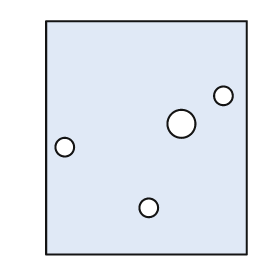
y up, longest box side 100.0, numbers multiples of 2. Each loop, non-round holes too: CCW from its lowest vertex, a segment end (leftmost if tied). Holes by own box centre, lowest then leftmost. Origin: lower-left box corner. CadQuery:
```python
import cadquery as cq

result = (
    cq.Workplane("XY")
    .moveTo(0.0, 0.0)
    .lineTo(86.0, 0.0)
    .lineTo(86.0, 100.0)
    .lineTo(0.0, 100.0)
    .close()
    .moveTo(44.0, 20.0)
    .circle(4.0)
    .moveTo(8.0, 46.0)
    .circle(4.0)
    .moveTo(58.0, 56.0)
    .circle(6.0)
    .moveTo(76.0, 68.0)
    .circle(4.0)
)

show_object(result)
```